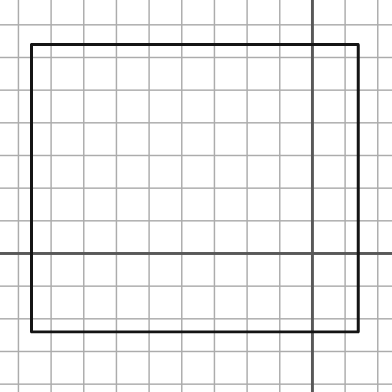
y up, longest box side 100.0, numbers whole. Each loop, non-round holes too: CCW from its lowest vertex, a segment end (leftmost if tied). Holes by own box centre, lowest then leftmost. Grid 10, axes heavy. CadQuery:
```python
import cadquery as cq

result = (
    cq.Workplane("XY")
    .moveTo(-86.0, -24.0)
    .lineTo(14.0, -24.0)
    .lineTo(14.0, 64.0)
    .lineTo(-86.0, 64.0)
    .close()
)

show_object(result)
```